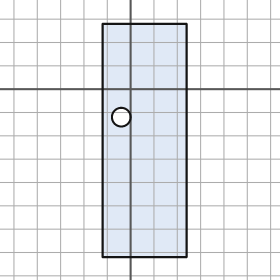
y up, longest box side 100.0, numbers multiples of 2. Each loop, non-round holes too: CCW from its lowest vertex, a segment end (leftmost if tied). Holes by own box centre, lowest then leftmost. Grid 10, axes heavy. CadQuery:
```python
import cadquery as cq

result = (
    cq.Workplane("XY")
    .moveTo(-12.0, -72.0)
    .lineTo(24.0, -72.0)
    .lineTo(24.0, 28.0)
    .lineTo(-12.0, 28.0)
    .close()
    .moveTo(-4.0, -12.0)
    .circle(4.0)
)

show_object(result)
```